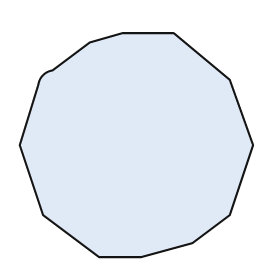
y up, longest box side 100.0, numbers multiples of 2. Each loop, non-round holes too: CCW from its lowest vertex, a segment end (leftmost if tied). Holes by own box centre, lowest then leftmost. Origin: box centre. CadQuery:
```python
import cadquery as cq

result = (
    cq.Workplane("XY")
    .moveTo(-16.0, -48.0)
    .lineTo(2.0, -48.0)
    .lineTo(24.0, -42.0)
    .lineTo(40.0, -30.0)
    .lineTo(50.0, 0.0)
    .lineTo(40.0, 28.0)
    .lineTo(16.0, 48.0)
    .lineTo(-6.0, 48.0)
    .lineTo(-20.0, 44.0)
    .lineTo(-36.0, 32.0)
    .threePointArc((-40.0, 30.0), (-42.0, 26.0))
    .lineTo(-50.0, 0.0)
    .lineTo(-40.0, -30.0)
    .close()
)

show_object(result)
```